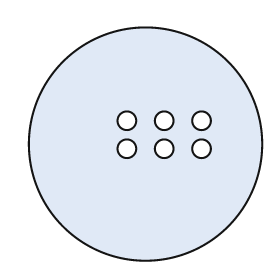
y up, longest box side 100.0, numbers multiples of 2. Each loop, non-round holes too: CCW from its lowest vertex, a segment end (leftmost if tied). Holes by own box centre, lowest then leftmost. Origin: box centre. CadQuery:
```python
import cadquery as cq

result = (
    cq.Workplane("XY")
    .moveTo(0.0, 0.0)
    .circle(50.0)
    .moveTo(-8.0, -2.0)
    .circle(4.0)
    .moveTo(8.0, -2.0)
    .circle(4.0)
    .moveTo(24.0, -2.0)
    .circle(4.0)
    .moveTo(-8.0, 10.0)
    .circle(4.0)
    .moveTo(8.0, 10.0)
    .circle(4.0)
    .moveTo(24.0, 10.0)
    .circle(4.0)
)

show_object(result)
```